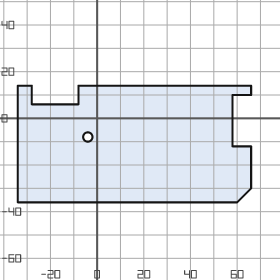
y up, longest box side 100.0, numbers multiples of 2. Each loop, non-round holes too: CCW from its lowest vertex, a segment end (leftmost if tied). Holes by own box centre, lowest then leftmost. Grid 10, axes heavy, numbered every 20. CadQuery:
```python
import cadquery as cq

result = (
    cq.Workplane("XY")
    .moveTo(-34.0, -36.0)
    .lineTo(60.0, -36.0)
    .lineTo(66.0, -30.0)
    .lineTo(66.0, -12.0)
    .lineTo(58.0, -12.0)
    .lineTo(58.0, 10.0)
    .lineTo(66.0, 10.0)
    .lineTo(66.0, 14.0)
    .lineTo(-8.0, 14.0)
    .lineTo(-8.0, 6.0)
    .lineTo(-28.0, 6.0)
    .lineTo(-28.0, 14.0)
    .lineTo(-34.0, 14.0)
    .close()
    .moveTo(-4.0, -8.0)
    .circle(2.0)
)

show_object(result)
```